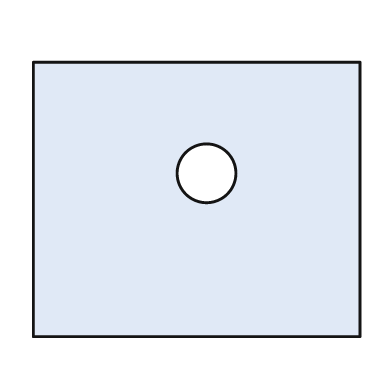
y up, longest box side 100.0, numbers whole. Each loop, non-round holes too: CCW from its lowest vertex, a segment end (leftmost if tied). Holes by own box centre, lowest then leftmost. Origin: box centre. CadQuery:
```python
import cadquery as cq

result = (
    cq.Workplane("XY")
    .moveTo(-50.0, -42.0)
    .lineTo(50.0, -42.0)
    .lineTo(50.0, 42.0)
    .lineTo(-50.0, 42.0)
    .close()
    .moveTo(3.0, 8.0)
    .circle(9.0)
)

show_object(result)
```